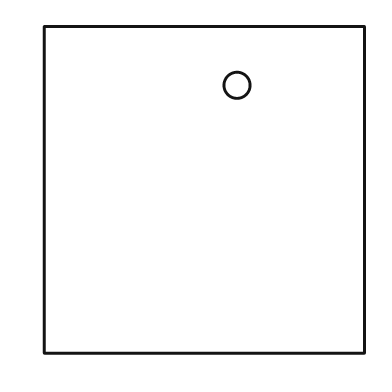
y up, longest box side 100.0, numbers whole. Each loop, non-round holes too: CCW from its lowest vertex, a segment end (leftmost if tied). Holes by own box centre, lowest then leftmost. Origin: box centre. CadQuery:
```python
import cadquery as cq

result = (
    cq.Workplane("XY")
    .moveTo(-49.0, -50.0)
    .lineTo(49.0, -50.0)
    .lineTo(49.0, 50.0)
    .lineTo(-49.0, 50.0)
    .close()
    .moveTo(10.0, 32.0)
    .circle(4.0)
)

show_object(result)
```